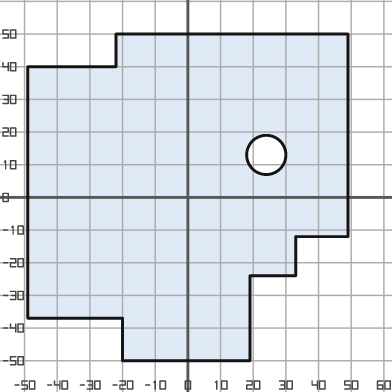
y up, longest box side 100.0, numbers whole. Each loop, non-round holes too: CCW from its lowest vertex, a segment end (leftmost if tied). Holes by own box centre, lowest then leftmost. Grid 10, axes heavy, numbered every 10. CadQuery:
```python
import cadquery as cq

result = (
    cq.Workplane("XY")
    .moveTo(-20.0, -50.0)
    .lineTo(19.0, -50.0)
    .lineTo(19.0, -24.0)
    .lineTo(33.0, -24.0)
    .lineTo(33.0, -12.0)
    .lineTo(49.0, -12.0)
    .lineTo(49.0, 50.0)
    .lineTo(-22.0, 50.0)
    .lineTo(-22.0, 40.0)
    .lineTo(-49.0, 40.0)
    .lineTo(-49.0, -37.0)
    .lineTo(-20.0, -37.0)
    .close()
    .moveTo(24.0, 13.0)
    .circle(6.0)
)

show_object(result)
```